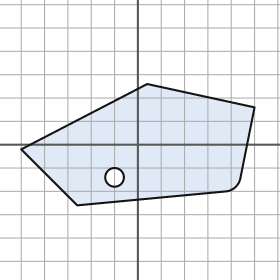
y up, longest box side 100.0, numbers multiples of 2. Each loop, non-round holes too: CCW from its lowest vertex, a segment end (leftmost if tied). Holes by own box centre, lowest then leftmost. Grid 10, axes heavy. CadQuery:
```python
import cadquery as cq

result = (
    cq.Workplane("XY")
    .moveTo(-26.0, -26.0)
    .lineTo(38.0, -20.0)
    .threePointArc((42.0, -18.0), (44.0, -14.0))
    .lineTo(50.0, 16.0)
    .lineTo(4.0, 26.0)
    .lineTo(-50.0, -2.0)
    .close()
    .moveTo(-10.0, -14.0)
    .circle(4.0)
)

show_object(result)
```